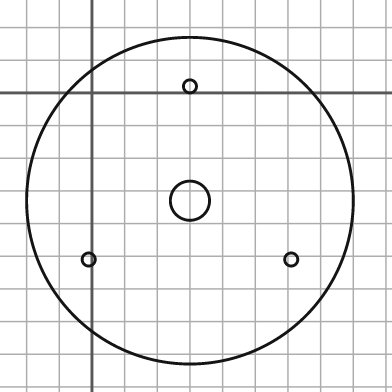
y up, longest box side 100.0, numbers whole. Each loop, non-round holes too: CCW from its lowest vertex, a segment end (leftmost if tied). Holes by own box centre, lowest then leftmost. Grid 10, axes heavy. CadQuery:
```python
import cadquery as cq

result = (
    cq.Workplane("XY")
    .moveTo(30.0, -33.0)
    .circle(50.0)
    .moveTo(-1.0, -51.0)
    .circle(2.0)
    .moveTo(61.0, -51.0)
    .circle(2.0)
    .moveTo(30.0, -33.0)
    .circle(6.0)
    .moveTo(30.0, 2.0)
    .circle(2.0)
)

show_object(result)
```